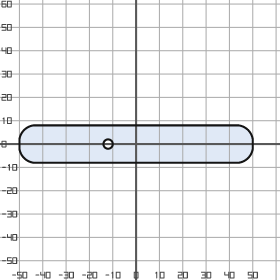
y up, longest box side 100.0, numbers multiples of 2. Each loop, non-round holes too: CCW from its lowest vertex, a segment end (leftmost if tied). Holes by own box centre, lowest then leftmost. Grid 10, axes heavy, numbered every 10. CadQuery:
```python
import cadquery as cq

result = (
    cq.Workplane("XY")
    .moveTo(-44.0, -8.0)
    .lineTo(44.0, -8.0)
    .threePointArc((48.0, -6.0), (50.0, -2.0))
    .lineTo(50.0, 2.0)
    .threePointArc((48.0, 6.0), (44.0, 8.0))
    .lineTo(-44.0, 8.0)
    .threePointArc((-48.0, 6.0), (-50.0, 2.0))
    .lineTo(-50.0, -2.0)
    .threePointArc((-48.0, -6.0), (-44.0, -8.0))
    .close()
    .moveTo(-12.0, 0.0)
    .circle(2.0)
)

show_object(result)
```